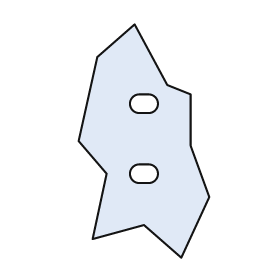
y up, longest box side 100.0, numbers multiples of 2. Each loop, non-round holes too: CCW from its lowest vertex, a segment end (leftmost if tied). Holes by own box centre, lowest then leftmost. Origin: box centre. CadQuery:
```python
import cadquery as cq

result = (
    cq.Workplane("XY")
    .moveTo(16.0, -50.0)
    .lineTo(28.0, -24.0)
    .lineTo(20.0, -2.0)
    .lineTo(20.0, 20.0)
    .lineTo(10.0, 24.0)
    .lineTo(-4.0, 50.0)
    .lineTo(-20.0, 36.0)
    .lineTo(-28.0, 0.0)
    .lineTo(-16.0, -14.0)
    .lineTo(-22.0, -42.0)
    .lineTo(0.0, -36.0)
    .close()
    .moveTo(-2.0, -18.0)
    .lineTo(2.0, -18.0)
    .threePointArc((6.0, -14.0), (2.0, -10.0))
    .lineTo(-2.0, -10.0)
    .threePointArc((-6.0, -14.0), (-2.0, -18.0))
    .close()
    .moveTo(-2.0, 12.0)
    .lineTo(2.0, 12.0)
    .threePointArc((6.0, 16.0), (2.0, 20.0))
    .lineTo(-2.0, 20.0)
    .threePointArc((-6.0, 16.0), (-2.0, 12.0))
    .close()
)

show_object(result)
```